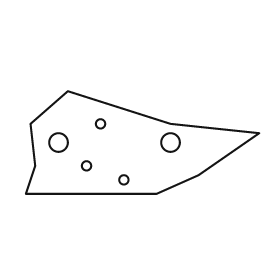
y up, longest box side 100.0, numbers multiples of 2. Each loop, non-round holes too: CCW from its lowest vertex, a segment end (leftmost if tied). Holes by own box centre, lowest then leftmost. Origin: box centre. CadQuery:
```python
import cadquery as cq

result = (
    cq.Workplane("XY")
    .moveTo(-50.0, -22.0)
    .lineTo(6.0, -22.0)
    .lineTo(24.0, -14.0)
    .lineTo(50.0, 4.0)
    .lineTo(12.0, 8.0)
    .lineTo(-32.0, 22.0)
    .lineTo(-48.0, 8.0)
    .lineTo(-46.0, -10.0)
    .close()
    .moveTo(-8.0, -16.0)
    .circle(2.0)
    .moveTo(-24.0, -10.0)
    .circle(2.0)
    .moveTo(-36.0, 0.0)
    .circle(4.0)
    .moveTo(12.0, 0.0)
    .circle(4.0)
    .moveTo(-18.0, 8.0)
    .circle(2.0)
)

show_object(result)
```